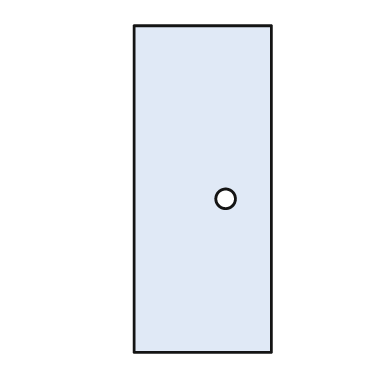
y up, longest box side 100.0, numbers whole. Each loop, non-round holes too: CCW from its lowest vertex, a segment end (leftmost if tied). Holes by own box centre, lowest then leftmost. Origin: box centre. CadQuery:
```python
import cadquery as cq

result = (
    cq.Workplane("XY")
    .moveTo(-21.0, -50.0)
    .lineTo(21.0, -50.0)
    .lineTo(21.0, 50.0)
    .lineTo(-21.0, 50.0)
    .close()
    .moveTo(7.0, -3.0)
    .circle(3.0)
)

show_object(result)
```